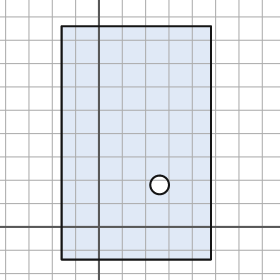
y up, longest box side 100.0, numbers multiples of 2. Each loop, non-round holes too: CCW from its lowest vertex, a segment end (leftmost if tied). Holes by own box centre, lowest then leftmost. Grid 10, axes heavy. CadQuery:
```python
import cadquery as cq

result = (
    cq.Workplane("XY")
    .moveTo(-16.0, -14.0)
    .lineTo(48.0, -14.0)
    .lineTo(48.0, 86.0)
    .lineTo(-16.0, 86.0)
    .close()
    .moveTo(26.0, 18.0)
    .circle(4.0)
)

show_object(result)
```